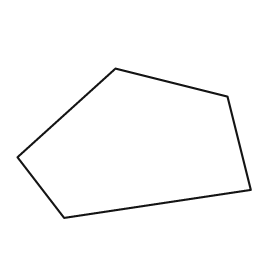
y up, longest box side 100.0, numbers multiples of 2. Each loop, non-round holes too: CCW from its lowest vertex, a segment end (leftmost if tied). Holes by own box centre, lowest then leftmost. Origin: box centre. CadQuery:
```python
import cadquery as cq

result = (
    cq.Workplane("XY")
    .moveTo(-30.0, -32.0)
    .lineTo(50.0, -20.0)
    .lineTo(40.0, 20.0)
    .lineTo(-8.0, 32.0)
    .lineTo(-50.0, -6.0)
    .close()
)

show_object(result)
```